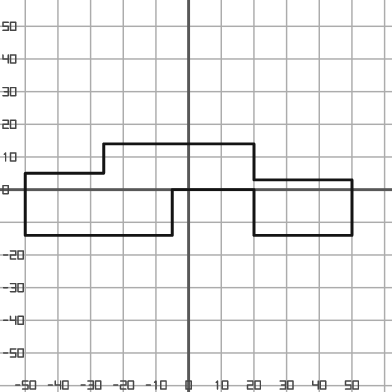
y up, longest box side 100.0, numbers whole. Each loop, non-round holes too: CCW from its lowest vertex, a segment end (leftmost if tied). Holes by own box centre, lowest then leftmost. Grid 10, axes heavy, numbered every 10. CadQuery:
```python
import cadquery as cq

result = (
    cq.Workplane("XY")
    .moveTo(-50.0, -14.0)
    .lineTo(-5.0, -14.0)
    .lineTo(-5.0, 0.0)
    .lineTo(20.0, 0.0)
    .lineTo(20.0, -14.0)
    .lineTo(50.0, -14.0)
    .lineTo(50.0, 3.0)
    .lineTo(20.0, 3.0)
    .lineTo(20.0, 14.0)
    .lineTo(-26.0, 14.0)
    .lineTo(-26.0, 5.0)
    .lineTo(-50.0, 5.0)
    .close()
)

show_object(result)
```